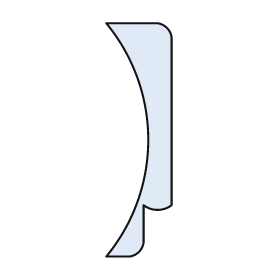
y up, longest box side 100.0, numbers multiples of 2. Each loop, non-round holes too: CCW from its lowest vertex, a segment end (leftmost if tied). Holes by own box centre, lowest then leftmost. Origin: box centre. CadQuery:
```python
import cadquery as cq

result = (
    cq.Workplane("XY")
    .moveTo(-14.0, -50.0)
    .lineTo(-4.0, -50.0)
    .threePointArc((0.0, -48.0), (2.0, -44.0))
    .lineTo(2.0, -28.0)
    .threePointArc((8.0, -30.0), (14.0, -28.0))
    .lineTo(14.0, 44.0)
    .threePointArc((12.0, 48.0), (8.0, 50.0))
    .lineTo(-14.0, 50.0)
    .threePointArc((4.0, 0.0), (-14.0, -50.0))
    .close()
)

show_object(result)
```